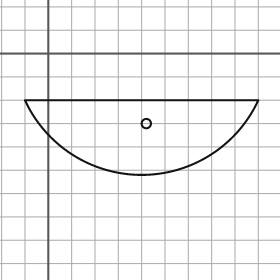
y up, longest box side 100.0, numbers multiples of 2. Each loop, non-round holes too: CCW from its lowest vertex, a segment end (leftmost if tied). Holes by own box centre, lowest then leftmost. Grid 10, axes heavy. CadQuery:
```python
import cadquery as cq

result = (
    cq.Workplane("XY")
    .moveTo(-10.0, -20.0)
    .threePointArc((40.0, -52.0), (90.0, -20.0))
    .close()
    .moveTo(42.0, -30.0)
    .circle(2.0)
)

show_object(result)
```